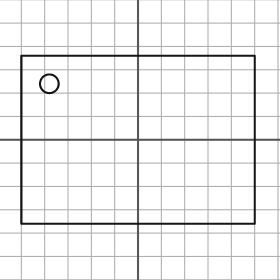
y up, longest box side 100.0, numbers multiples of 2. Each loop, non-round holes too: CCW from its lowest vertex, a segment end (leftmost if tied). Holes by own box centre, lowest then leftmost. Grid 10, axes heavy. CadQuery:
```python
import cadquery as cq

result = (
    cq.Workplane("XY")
    .moveTo(-50.0, -36.0)
    .lineTo(50.0, -36.0)
    .lineTo(50.0, 36.0)
    .lineTo(-50.0, 36.0)
    .close()
    .moveTo(-38.0, 24.0)
    .circle(4.0)
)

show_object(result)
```